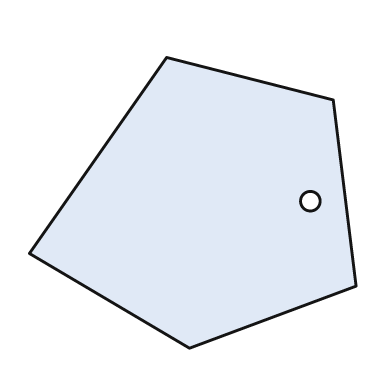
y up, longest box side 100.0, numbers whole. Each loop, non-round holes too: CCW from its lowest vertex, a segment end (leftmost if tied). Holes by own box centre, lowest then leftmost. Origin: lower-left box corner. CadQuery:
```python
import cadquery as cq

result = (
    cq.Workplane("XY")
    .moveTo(49.0, 0.0)
    .lineTo(100.0, 19.0)
    .lineTo(93.0, 76.0)
    .lineTo(42.0, 89.0)
    .lineTo(0.0, 29.0)
    .close()
    .moveTo(86.0, 45.0)
    .circle(3.0)
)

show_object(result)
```